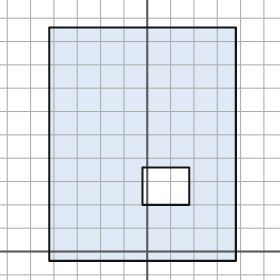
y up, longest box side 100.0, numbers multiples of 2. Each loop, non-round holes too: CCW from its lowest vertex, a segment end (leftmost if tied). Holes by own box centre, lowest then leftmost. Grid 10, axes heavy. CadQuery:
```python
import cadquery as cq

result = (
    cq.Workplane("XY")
    .moveTo(-42.0, -4.0)
    .lineTo(38.0, -4.0)
    .lineTo(38.0, 96.0)
    .lineTo(-42.0, 96.0)
    .close()
    .moveTo(-2.0, 20.0)
    .lineTo(18.0, 20.0)
    .lineTo(18.0, 36.0)
    .lineTo(-2.0, 36.0)
    .close()
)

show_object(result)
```